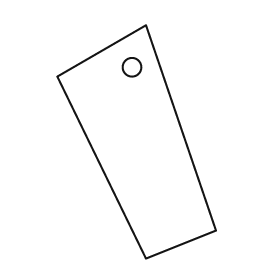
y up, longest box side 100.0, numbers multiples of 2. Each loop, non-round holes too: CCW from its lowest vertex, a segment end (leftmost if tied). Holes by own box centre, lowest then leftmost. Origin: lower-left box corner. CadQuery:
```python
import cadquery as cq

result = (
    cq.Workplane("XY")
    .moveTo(38.0, 0.0)
    .lineTo(68.0, 12.0)
    .lineTo(38.0, 100.0)
    .lineTo(0.0, 78.0)
    .close()
    .moveTo(32.0, 82.0)
    .circle(4.0)
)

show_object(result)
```